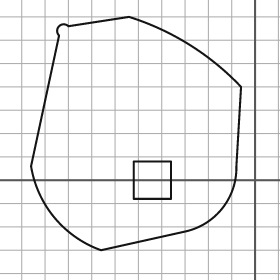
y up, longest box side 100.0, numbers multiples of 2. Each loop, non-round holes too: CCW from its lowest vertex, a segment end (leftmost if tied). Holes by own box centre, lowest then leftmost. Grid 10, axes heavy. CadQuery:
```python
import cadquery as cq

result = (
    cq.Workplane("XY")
    .moveTo(-66.0, -30.0)
    .lineTo(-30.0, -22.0)
    .threePointArc((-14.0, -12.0), (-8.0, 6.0))
    .lineTo(-6.0, 40.0)
    .threePointArc((-28.0, 58.0), (-54.0, 70.0))
    .lineTo(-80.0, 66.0)
    .threePointArc((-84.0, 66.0), (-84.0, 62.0))
    .lineTo(-96.0, 6.0)
    .threePointArc((-86.0, -16.0), (-66.0, -30.0))
    .close()
    .moveTo(-52.0, -8.0)
    .lineTo(-36.0, -8.0)
    .lineTo(-36.0, 8.0)
    .lineTo(-52.0, 8.0)
    .close()
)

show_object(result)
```